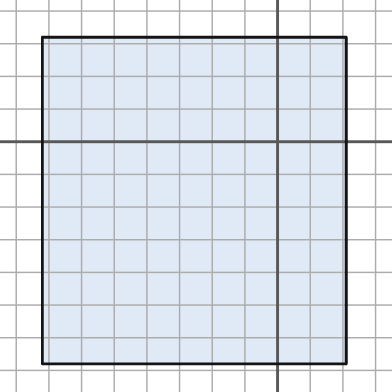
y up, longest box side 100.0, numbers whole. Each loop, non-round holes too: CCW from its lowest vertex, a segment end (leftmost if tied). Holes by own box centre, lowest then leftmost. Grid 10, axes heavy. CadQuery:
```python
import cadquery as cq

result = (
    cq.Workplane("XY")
    .moveTo(-72.0, -68.0)
    .lineTo(21.0, -68.0)
    .lineTo(21.0, 32.0)
    .lineTo(-72.0, 32.0)
    .close()
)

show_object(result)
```